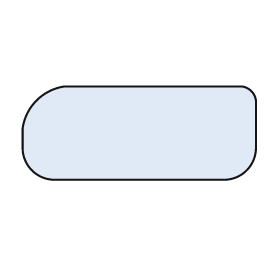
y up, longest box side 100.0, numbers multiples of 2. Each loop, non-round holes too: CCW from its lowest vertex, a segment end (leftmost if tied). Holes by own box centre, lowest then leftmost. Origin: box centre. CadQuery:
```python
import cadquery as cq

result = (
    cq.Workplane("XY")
    .moveTo(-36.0, -20.0)
    .lineTo(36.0, -20.0)
    .threePointArc((46.0, -16.0), (50.0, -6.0))
    .lineTo(50.0, 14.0)
    .threePointArc((48.0, 18.0), (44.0, 20.0))
    .lineTo(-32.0, 20.0)
    .threePointArc((-44.0, 14.0), (-50.0, 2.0))
    .lineTo(-50.0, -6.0)
    .threePointArc((-46.0, -16.0), (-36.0, -20.0))
    .close()
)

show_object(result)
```